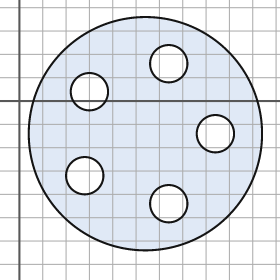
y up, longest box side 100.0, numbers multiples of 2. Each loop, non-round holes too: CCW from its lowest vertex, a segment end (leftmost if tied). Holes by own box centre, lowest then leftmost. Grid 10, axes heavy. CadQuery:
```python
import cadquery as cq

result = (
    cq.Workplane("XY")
    .moveTo(54.0, -14.0)
    .circle(50.0)
    .moveTo(64.0, -44.0)
    .circle(8.0)
    .moveTo(28.0, -32.0)
    .circle(8.0)
    .moveTo(84.0, -14.0)
    .circle(8.0)
    .moveTo(30.0, 4.0)
    .circle(8.0)
    .moveTo(64.0, 16.0)
    .circle(8.0)
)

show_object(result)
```